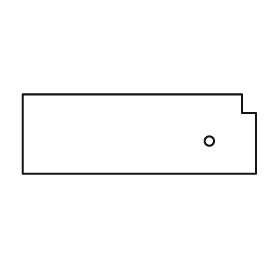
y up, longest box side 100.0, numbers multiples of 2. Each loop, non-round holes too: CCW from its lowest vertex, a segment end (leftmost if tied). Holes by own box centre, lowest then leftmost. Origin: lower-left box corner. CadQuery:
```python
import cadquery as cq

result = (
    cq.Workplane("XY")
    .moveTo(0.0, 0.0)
    .lineTo(100.0, 0.0)
    .lineTo(100.0, 26.0)
    .lineTo(94.0, 26.0)
    .lineTo(94.0, 34.0)
    .lineTo(0.0, 34.0)
    .close()
    .moveTo(80.0, 14.0)
    .circle(2.0)
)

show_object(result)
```